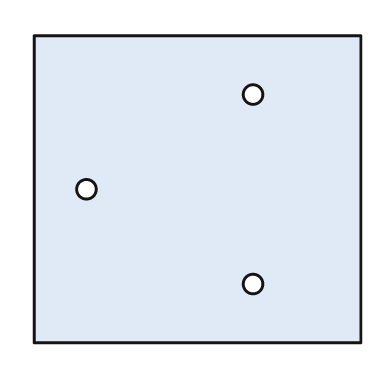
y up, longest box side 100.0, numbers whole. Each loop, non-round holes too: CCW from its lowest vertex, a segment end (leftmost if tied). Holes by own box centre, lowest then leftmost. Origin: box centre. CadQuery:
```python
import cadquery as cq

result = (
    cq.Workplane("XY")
    .moveTo(-50.0, -47.0)
    .lineTo(50.0, -47.0)
    .lineTo(50.0, 47.0)
    .lineTo(-50.0, 47.0)
    .close()
    .moveTo(17.0, -29.0)
    .circle(3.0)
    .moveTo(-34.0, 0.0)
    .circle(3.0)
    .moveTo(17.0, 29.0)
    .circle(3.0)
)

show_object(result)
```